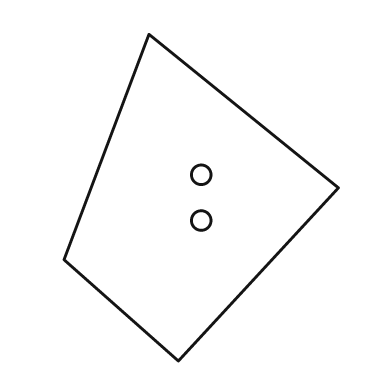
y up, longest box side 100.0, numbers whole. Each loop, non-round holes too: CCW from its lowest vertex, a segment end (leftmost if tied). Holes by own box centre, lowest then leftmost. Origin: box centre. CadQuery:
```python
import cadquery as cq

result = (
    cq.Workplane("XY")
    .moveTo(-7.0, -50.0)
    .lineTo(42.0, 3.0)
    .lineTo(-16.0, 50.0)
    .lineTo(-42.0, -19.0)
    .close()
    .moveTo(0.0, -7.0)
    .circle(3.0)
    .moveTo(0.0, 7.0)
    .circle(3.0)
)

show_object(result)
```